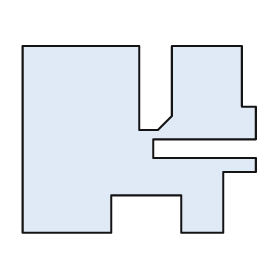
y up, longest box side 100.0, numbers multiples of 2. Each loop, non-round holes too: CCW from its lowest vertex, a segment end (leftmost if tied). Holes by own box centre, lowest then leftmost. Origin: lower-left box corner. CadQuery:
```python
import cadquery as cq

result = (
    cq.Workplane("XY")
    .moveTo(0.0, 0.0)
    .lineTo(38.0, 0.0)
    .lineTo(38.0, 16.0)
    .lineTo(68.0, 16.0)
    .lineTo(68.0, 0.0)
    .lineTo(86.0, 0.0)
    .lineTo(86.0, 26.0)
    .lineTo(100.0, 26.0)
    .lineTo(100.0, 32.0)
    .lineTo(56.0, 32.0)
    .lineTo(56.0, 40.0)
    .lineTo(100.0, 40.0)
    .lineTo(100.0, 54.0)
    .lineTo(94.0, 54.0)
    .lineTo(94.0, 80.0)
    .lineTo(64.0, 80.0)
    .lineTo(64.0, 50.0)
    .lineTo(58.0, 44.0)
    .lineTo(50.0, 44.0)
    .lineTo(50.0, 80.0)
    .lineTo(0.0, 80.0)
    .close()
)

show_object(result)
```